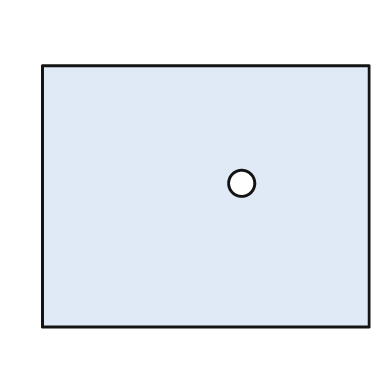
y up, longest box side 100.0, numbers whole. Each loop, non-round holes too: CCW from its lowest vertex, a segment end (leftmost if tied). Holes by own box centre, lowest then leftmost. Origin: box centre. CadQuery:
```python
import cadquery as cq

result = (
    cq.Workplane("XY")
    .moveTo(-50.0, -40.0)
    .lineTo(50.0, -40.0)
    .lineTo(50.0, 40.0)
    .lineTo(-50.0, 40.0)
    .close()
    .moveTo(11.0, 4.0)
    .circle(4.0)
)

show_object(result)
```